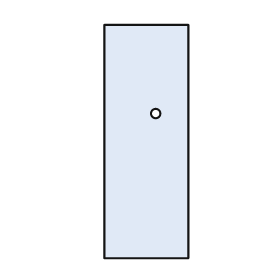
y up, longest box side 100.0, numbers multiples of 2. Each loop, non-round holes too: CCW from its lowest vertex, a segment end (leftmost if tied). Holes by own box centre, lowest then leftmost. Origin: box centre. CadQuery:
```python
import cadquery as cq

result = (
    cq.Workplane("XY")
    .moveTo(-18.0, -50.0)
    .lineTo(18.0, -50.0)
    .lineTo(18.0, 50.0)
    .lineTo(-18.0, 50.0)
    .close()
    .moveTo(4.0, 12.0)
    .circle(2.0)
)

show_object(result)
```